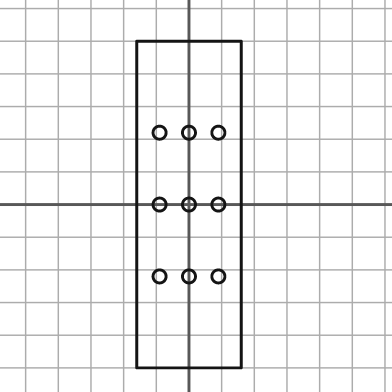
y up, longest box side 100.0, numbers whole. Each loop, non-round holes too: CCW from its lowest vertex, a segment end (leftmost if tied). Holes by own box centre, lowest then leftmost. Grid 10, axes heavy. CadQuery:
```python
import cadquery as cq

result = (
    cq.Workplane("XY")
    .moveTo(-16.0, -50.0)
    .lineTo(16.0, -50.0)
    .lineTo(16.0, 50.0)
    .lineTo(-16.0, 50.0)
    .close()
    .moveTo(-9.0, -22.0)
    .circle(2.0)
    .moveTo(0.0, -22.0)
    .circle(2.0)
    .moveTo(9.0, -22.0)
    .circle(2.0)
    .moveTo(-9.0, 0.0)
    .circle(2.0)
    .moveTo(0.0, 0.0)
    .circle(2.0)
    .moveTo(9.0, 0.0)
    .circle(2.0)
    .moveTo(-9.0, 22.0)
    .circle(2.0)
    .moveTo(0.0, 22.0)
    .circle(2.0)
    .moveTo(9.0, 22.0)
    .circle(2.0)
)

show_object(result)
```